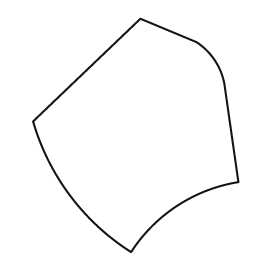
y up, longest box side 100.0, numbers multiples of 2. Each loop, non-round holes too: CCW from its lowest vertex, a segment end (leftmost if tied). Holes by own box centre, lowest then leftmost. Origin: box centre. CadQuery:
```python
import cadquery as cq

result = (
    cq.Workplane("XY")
    .moveTo(-2.0, -50.0)
    .threePointArc((18.0, -30.0), (44.0, -20.0))
    .lineTo(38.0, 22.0)
    .threePointArc((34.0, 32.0), (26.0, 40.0))
    .lineTo(2.0, 50.0)
    .lineTo(-44.0, 6.0)
    .threePointArc((-28.0, -26.0), (-2.0, -50.0))
    .close()
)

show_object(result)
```